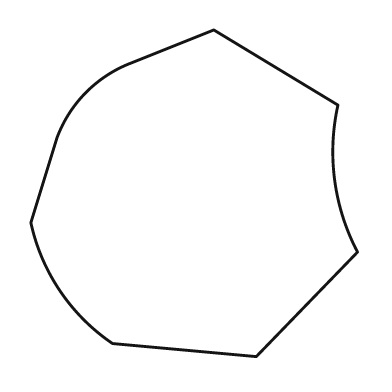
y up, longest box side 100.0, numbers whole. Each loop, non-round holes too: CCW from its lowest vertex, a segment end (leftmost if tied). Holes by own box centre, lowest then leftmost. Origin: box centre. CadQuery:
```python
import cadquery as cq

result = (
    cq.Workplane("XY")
    .moveTo(19.0, -50.0)
    .lineTo(50.0, -18.0)
    .threePointArc((43.0, 4.0), (44.0, 27.0))
    .lineTo(6.0, 50.0)
    .lineTo(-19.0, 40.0)
    .threePointArc((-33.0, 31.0), (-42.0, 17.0))
    .lineTo(-50.0, -9.0)
    .threePointArc((-41.0, -30.0), (-25.0, -46.0))
    .close()
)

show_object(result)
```